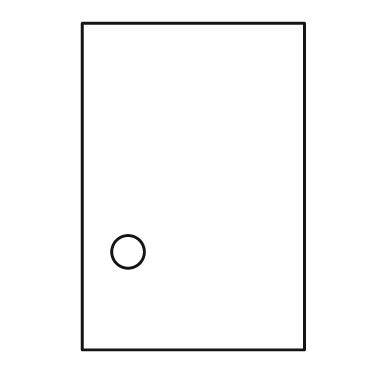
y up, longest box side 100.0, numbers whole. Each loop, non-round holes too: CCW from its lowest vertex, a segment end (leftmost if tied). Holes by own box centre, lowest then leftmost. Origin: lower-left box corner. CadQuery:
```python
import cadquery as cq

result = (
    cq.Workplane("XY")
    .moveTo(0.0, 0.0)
    .lineTo(68.0, 0.0)
    .lineTo(68.0, 100.0)
    .lineTo(0.0, 100.0)
    .close()
    .moveTo(14.0, 30.0)
    .circle(5.0)
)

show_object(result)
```